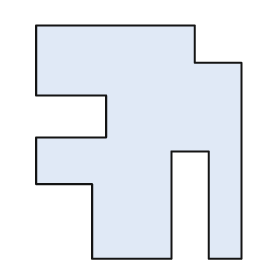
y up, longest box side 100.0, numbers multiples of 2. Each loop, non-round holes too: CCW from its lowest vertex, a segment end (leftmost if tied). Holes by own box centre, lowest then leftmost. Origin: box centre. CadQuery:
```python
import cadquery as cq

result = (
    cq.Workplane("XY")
    .moveTo(-20.0, -50.0)
    .lineTo(14.0, -50.0)
    .lineTo(14.0, -4.0)
    .lineTo(30.0, -4.0)
    .lineTo(30.0, -50.0)
    .lineTo(44.0, -50.0)
    .lineTo(44.0, 34.0)
    .lineTo(24.0, 34.0)
    .lineTo(24.0, 50.0)
    .lineTo(-44.0, 50.0)
    .lineTo(-44.0, 20.0)
    .lineTo(-14.0, 20.0)
    .lineTo(-14.0, 2.0)
    .lineTo(-44.0, 2.0)
    .lineTo(-44.0, -18.0)
    .lineTo(-20.0, -18.0)
    .close()
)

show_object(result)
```